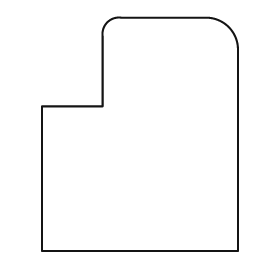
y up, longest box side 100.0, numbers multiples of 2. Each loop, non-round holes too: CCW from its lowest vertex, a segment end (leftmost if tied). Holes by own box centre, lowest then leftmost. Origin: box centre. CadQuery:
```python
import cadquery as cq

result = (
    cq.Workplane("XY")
    .moveTo(-42.0, -50.0)
    .lineTo(42.0, -50.0)
    .lineTo(42.0, 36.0)
    .threePointArc((38.0, 46.0), (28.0, 50.0))
    .lineTo(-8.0, 50.0)
    .threePointArc((-14.0, 48.0), (-16.0, 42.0))
    .lineTo(-16.0, 12.0)
    .lineTo(-42.0, 12.0)
    .close()
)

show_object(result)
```